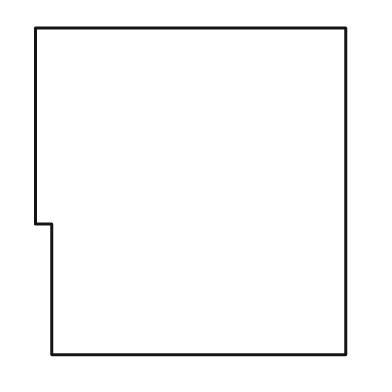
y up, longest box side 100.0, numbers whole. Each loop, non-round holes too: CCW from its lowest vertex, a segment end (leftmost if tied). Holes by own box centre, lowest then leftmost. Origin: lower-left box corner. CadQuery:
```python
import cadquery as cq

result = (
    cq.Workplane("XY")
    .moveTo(5.0, 0.0)
    .lineTo(95.0, 0.0)
    .lineTo(95.0, 100.0)
    .lineTo(0.0, 100.0)
    .lineTo(0.0, 40.0)
    .lineTo(5.0, 40.0)
    .close()
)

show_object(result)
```